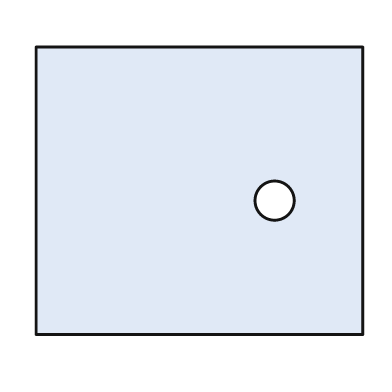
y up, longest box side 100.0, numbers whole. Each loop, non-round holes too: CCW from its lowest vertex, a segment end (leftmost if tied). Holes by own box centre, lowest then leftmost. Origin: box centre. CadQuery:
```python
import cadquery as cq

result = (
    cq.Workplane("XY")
    .moveTo(-50.0, -44.0)
    .lineTo(50.0, -44.0)
    .lineTo(50.0, 44.0)
    .lineTo(-50.0, 44.0)
    .close()
    .moveTo(23.0, -3.0)
    .circle(6.0)
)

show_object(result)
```